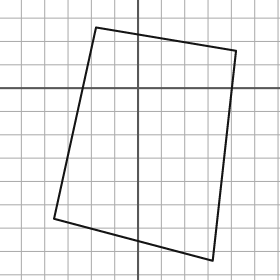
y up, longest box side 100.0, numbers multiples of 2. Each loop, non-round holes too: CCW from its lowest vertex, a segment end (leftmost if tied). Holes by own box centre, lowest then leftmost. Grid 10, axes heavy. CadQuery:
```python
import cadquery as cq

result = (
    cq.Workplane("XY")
    .moveTo(32.0, -74.0)
    .lineTo(42.0, 16.0)
    .lineTo(-18.0, 26.0)
    .lineTo(-36.0, -56.0)
    .close()
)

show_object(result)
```